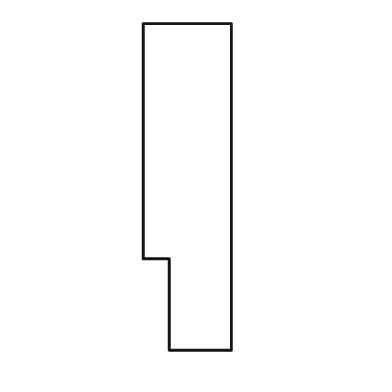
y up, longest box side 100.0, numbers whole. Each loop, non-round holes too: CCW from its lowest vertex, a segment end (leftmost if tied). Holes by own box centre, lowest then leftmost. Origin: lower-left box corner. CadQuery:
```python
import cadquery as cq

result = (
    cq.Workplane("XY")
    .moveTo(8.0, 0.0)
    .lineTo(27.0, 0.0)
    .lineTo(27.0, 100.0)
    .lineTo(0.0, 100.0)
    .lineTo(0.0, 28.0)
    .lineTo(8.0, 28.0)
    .close()
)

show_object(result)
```